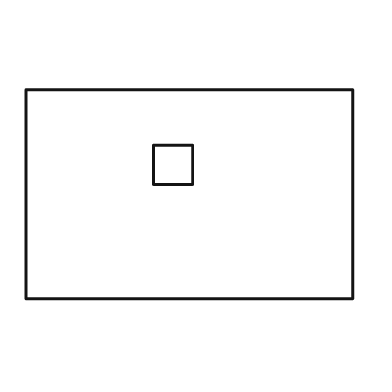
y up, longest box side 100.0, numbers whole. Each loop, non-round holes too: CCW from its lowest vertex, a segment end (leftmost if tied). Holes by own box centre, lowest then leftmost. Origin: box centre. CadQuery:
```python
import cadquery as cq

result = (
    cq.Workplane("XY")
    .moveTo(-50.0, -32.0)
    .lineTo(50.0, -32.0)
    .lineTo(50.0, 32.0)
    .lineTo(-50.0, 32.0)
    .close()
    .moveTo(-11.0, 3.0)
    .lineTo(1.0, 3.0)
    .lineTo(1.0, 15.0)
    .lineTo(-11.0, 15.0)
    .close()
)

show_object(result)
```